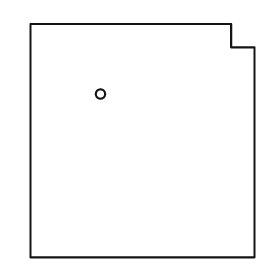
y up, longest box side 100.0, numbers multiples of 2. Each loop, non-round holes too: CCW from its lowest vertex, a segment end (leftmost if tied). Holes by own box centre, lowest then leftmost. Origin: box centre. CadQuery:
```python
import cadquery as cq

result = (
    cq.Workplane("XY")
    .moveTo(-48.0, -50.0)
    .lineTo(48.0, -50.0)
    .lineTo(48.0, 40.0)
    .lineTo(38.0, 40.0)
    .lineTo(38.0, 50.0)
    .lineTo(-48.0, 50.0)
    .close()
    .moveTo(-18.0, 20.0)
    .circle(2.0)
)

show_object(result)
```